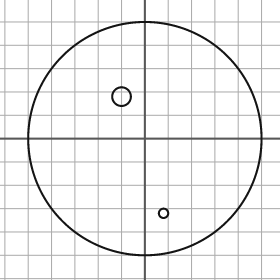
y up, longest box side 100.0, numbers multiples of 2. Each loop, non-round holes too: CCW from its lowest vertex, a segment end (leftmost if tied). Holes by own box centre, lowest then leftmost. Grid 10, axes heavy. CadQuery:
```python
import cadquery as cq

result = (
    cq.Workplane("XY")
    .moveTo(0.0, 0.0)
    .circle(50.0)
    .moveTo(8.0, -32.0)
    .circle(2.0)
    .moveTo(-10.0, 18.0)
    .circle(4.0)
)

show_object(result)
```